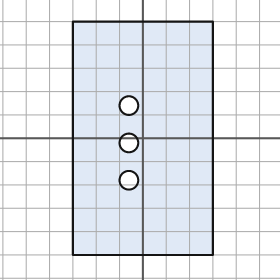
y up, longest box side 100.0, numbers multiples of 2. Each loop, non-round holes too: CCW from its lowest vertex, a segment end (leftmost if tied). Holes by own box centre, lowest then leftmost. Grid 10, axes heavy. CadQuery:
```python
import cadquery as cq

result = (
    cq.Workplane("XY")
    .moveTo(-30.0, -50.0)
    .lineTo(30.0, -50.0)
    .lineTo(30.0, 50.0)
    .lineTo(-30.0, 50.0)
    .close()
    .moveTo(-6.0, -18.0)
    .circle(4.0)
    .moveTo(-6.0, -2.0)
    .circle(4.0)
    .moveTo(-6.0, 14.0)
    .circle(4.0)
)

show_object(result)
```